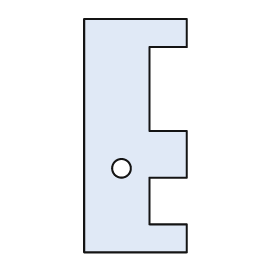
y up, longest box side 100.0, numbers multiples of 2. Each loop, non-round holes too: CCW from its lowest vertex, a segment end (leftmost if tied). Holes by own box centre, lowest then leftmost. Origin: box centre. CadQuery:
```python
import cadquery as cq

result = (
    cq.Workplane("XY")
    .moveTo(-22.0, -50.0)
    .lineTo(22.0, -50.0)
    .lineTo(22.0, -38.0)
    .lineTo(6.0, -38.0)
    .lineTo(6.0, -18.0)
    .lineTo(22.0, -18.0)
    .lineTo(22.0, 2.0)
    .lineTo(6.0, 2.0)
    .lineTo(6.0, 38.0)
    .lineTo(22.0, 38.0)
    .lineTo(22.0, 50.0)
    .lineTo(-22.0, 50.0)
    .close()
    .moveTo(-6.0, -14.0)
    .circle(4.0)
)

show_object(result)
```